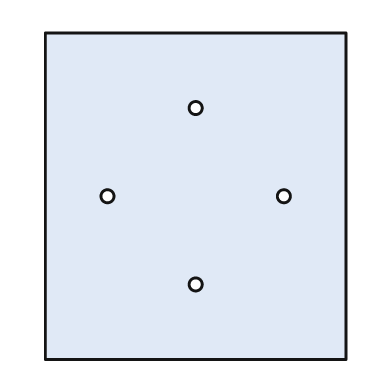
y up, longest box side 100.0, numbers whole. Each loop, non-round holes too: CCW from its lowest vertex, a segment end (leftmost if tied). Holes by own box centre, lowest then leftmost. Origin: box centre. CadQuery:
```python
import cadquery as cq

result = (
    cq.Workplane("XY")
    .moveTo(-46.0, -50.0)
    .lineTo(46.0, -50.0)
    .lineTo(46.0, 50.0)
    .lineTo(-46.0, 50.0)
    .close()
    .moveTo(0.0, -27.0)
    .circle(2.0)
    .moveTo(-27.0, 0.0)
    .circle(2.0)
    .moveTo(27.0, 0.0)
    .circle(2.0)
    .moveTo(0.0, 27.0)
    .circle(2.0)
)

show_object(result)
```